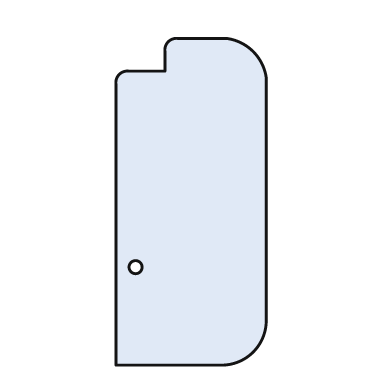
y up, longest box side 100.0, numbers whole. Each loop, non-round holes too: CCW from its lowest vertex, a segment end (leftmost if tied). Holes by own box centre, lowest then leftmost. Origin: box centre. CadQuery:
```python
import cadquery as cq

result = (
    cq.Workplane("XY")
    .moveTo(-23.0, -50.0)
    .lineTo(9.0, -50.0)
    .threePointArc((19.0, -46.0), (23.0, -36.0))
    .lineTo(23.0, 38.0)
    .threePointArc((19.0, 46.0), (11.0, 50.0))
    .lineTo(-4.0, 50.0)
    .threePointArc((-7.0, 49.0), (-8.0, 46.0))
    .lineTo(-8.0, 40.0)
    .lineTo(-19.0, 40.0)
    .threePointArc((-22.0, 39.0), (-23.0, 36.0))
    .close()
    .moveTo(-17.0, -20.0)
    .circle(2.0)
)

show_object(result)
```